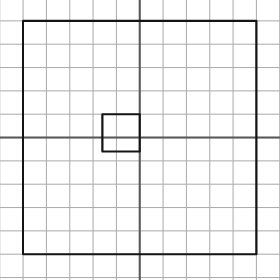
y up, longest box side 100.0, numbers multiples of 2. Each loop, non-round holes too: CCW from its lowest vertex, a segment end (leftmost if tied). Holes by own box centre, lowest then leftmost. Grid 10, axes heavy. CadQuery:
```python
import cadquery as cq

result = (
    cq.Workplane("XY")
    .moveTo(-50.0, -50.0)
    .lineTo(50.0, -50.0)
    .lineTo(50.0, 50.0)
    .lineTo(-50.0, 50.0)
    .close()
    .moveTo(-16.0, -6.0)
    .lineTo(0.0, -6.0)
    .lineTo(0.0, 10.0)
    .lineTo(-16.0, 10.0)
    .close()
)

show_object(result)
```